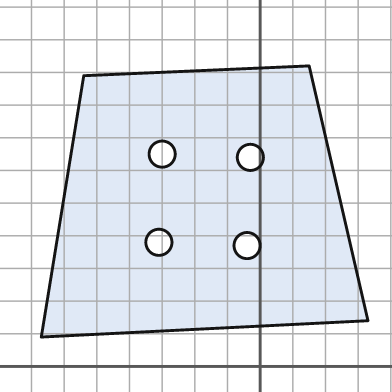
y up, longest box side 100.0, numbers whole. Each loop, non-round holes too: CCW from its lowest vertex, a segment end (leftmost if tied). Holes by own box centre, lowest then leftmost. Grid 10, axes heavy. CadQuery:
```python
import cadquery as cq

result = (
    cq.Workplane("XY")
    .moveTo(-67.0, 9.0)
    .lineTo(33.0, 14.0)
    .lineTo(15.0, 92.0)
    .lineTo(-54.0, 89.0)
    .close()
    .moveTo(-4.0, 37.0)
    .circle(4.0)
    .moveTo(-31.0, 38.0)
    .circle(4.0)
    .moveTo(-3.0, 64.0)
    .circle(4.0)
    .moveTo(-30.0, 65.0)
    .circle(4.0)
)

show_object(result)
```